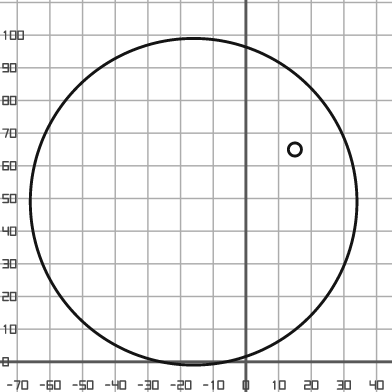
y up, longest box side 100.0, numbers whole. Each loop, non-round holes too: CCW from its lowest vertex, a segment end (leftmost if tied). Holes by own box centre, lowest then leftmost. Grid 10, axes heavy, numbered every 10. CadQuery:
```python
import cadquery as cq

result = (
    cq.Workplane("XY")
    .moveTo(-16.0, 49.0)
    .circle(50.0)
    .moveTo(15.0, 65.0)
    .circle(2.0)
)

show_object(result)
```